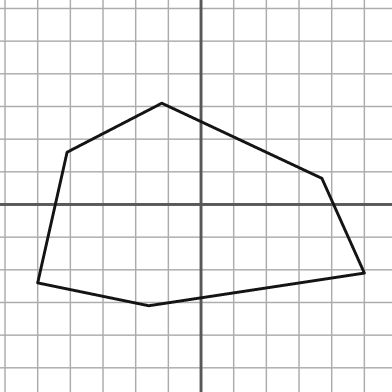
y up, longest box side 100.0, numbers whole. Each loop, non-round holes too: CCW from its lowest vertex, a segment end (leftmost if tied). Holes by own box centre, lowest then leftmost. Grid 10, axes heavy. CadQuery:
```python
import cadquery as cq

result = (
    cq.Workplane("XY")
    .moveTo(-16.0, -31.0)
    .lineTo(50.0, -21.0)
    .lineTo(37.0, 8.0)
    .lineTo(-12.0, 31.0)
    .lineTo(-41.0, 16.0)
    .lineTo(-50.0, -24.0)
    .close()
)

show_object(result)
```